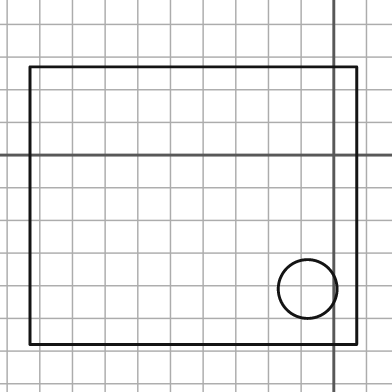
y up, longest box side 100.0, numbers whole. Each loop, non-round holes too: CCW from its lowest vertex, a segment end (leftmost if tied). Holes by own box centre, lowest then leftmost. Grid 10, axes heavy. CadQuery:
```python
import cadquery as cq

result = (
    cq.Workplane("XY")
    .moveTo(-93.0, -58.0)
    .lineTo(7.0, -58.0)
    .lineTo(7.0, 27.0)
    .lineTo(-93.0, 27.0)
    .close()
    .moveTo(-8.0, -41.0)
    .circle(9.0)
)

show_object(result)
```